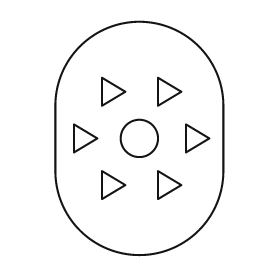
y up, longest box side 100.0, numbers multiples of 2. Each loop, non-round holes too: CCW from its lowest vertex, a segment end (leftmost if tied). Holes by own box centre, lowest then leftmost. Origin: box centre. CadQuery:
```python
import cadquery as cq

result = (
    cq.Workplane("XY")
    .moveTo(-36.0, -14.0)
    .threePointArc((0.0, -50.0), (36.0, -14.0))
    .lineTo(36.0, 14.0)
    .threePointArc((0.0, 50.0), (-36.0, 14.0))
    .close()
    .moveTo(-16.0, -26.0)
    .lineTo(-6.0, -20.0)
    .lineTo(-16.0, -14.0)
    .close()
    .moveTo(8.0, -26.0)
    .lineTo(18.0, -20.0)
    .lineTo(8.0, -14.0)
    .close()
    .moveTo(-28.0, -6.0)
    .lineTo(-18.0, 0.0)
    .lineTo(-28.0, 6.0)
    .close()
    .moveTo(0.0, 0.0)
    .circle(8.0)
    .moveTo(20.0, -6.0)
    .lineTo(30.0, 0.0)
    .lineTo(20.0, 6.0)
    .close()
    .moveTo(-16.0, 14.0)
    .lineTo(-6.0, 20.0)
    .lineTo(-16.0, 26.0)
    .close()
    .moveTo(8.0, 14.0)
    .lineTo(18.0, 20.0)
    .lineTo(8.0, 26.0)
    .close()
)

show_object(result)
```